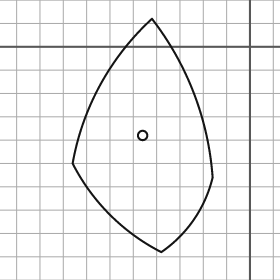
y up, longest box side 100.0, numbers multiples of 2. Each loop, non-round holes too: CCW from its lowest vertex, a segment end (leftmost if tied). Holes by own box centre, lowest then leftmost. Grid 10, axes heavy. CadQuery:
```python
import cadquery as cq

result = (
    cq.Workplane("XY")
    .moveTo(-38.0, -88.0)
    .threePointArc((-24.0, -74.0), (-16.0, -56.0))
    .threePointArc((-24.0, -20.0), (-42.0, 12.0))
    .threePointArc((-64.0, -16.0), (-76.0, -50.0))
    .threePointArc((-60.0, -72.0), (-38.0, -88.0))
    .close()
    .moveTo(-46.0, -38.0)
    .circle(2.0)
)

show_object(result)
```